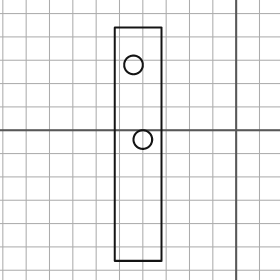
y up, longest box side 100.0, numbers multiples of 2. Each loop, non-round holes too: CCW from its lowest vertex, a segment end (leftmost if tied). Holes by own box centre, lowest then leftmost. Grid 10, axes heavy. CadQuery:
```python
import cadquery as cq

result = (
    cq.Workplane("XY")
    .moveTo(-52.0, -56.0)
    .lineTo(-32.0, -56.0)
    .lineTo(-32.0, 44.0)
    .lineTo(-52.0, 44.0)
    .close()
    .moveTo(-40.0, -4.0)
    .circle(4.0)
    .moveTo(-44.0, 28.0)
    .circle(4.0)
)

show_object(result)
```